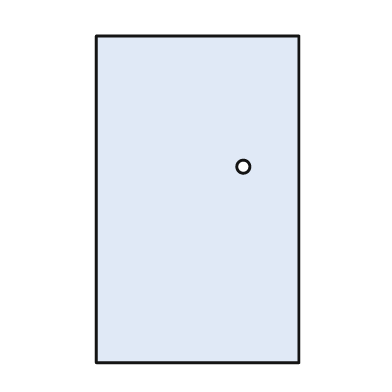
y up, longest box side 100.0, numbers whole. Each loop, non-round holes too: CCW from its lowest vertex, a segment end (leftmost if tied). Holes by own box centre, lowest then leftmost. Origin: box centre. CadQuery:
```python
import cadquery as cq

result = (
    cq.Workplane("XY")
    .moveTo(-31.0, -50.0)
    .lineTo(31.0, -50.0)
    .lineTo(31.0, 50.0)
    .lineTo(-31.0, 50.0)
    .close()
    .moveTo(14.0, 10.0)
    .circle(2.0)
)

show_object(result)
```